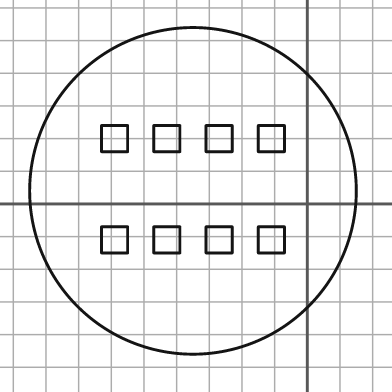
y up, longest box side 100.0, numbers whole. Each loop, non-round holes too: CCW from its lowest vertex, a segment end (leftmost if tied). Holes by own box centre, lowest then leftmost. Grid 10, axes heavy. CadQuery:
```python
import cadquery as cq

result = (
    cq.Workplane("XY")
    .moveTo(-35.0, 4.0)
    .circle(50.0)
    .moveTo(-63.0, -15.0)
    .lineTo(-55.0, -15.0)
    .lineTo(-55.0, -7.0)
    .lineTo(-63.0, -7.0)
    .close()
    .moveTo(-47.0, -15.0)
    .lineTo(-39.0, -15.0)
    .lineTo(-39.0, -7.0)
    .lineTo(-47.0, -7.0)
    .close()
    .moveTo(-31.0, -15.0)
    .lineTo(-23.0, -15.0)
    .lineTo(-23.0, -7.0)
    .lineTo(-31.0, -7.0)
    .close()
    .moveTo(-15.0, -15.0)
    .lineTo(-7.0, -15.0)
    .lineTo(-7.0, -7.0)
    .lineTo(-15.0, -7.0)
    .close()
    .moveTo(-63.0, 16.0)
    .lineTo(-55.0, 16.0)
    .lineTo(-55.0, 24.0)
    .lineTo(-63.0, 24.0)
    .close()
    .moveTo(-47.0, 16.0)
    .lineTo(-39.0, 16.0)
    .lineTo(-39.0, 24.0)
    .lineTo(-47.0, 24.0)
    .close()
    .moveTo(-31.0, 16.0)
    .lineTo(-23.0, 16.0)
    .lineTo(-23.0, 24.0)
    .lineTo(-31.0, 24.0)
    .close()
    .moveTo(-15.0, 16.0)
    .lineTo(-7.0, 16.0)
    .lineTo(-7.0, 24.0)
    .lineTo(-15.0, 24.0)
    .close()
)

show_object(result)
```